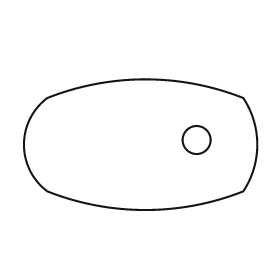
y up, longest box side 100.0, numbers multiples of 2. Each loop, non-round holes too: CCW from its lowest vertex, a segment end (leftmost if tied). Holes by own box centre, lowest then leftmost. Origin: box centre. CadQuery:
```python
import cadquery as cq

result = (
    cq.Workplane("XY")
    .moveTo(-40.0, -20.0)
    .threePointArc((2.0, -28.0), (44.0, -20.0))
    .threePointArc((50.0, 0.0), (44.0, 20.0))
    .threePointArc((2.0, 28.0), (-40.0, 20.0))
    .threePointArc((-50.0, 0.0), (-40.0, -20.0))
    .close()
    .moveTo(24.0, 2.0)
    .circle(6.0)
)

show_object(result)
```